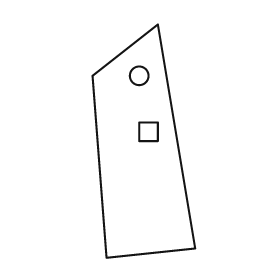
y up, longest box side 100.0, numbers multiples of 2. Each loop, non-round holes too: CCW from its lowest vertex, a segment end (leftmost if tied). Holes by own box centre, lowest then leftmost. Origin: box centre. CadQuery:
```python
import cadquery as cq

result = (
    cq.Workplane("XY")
    .moveTo(-16.0, -50.0)
    .lineTo(22.0, -46.0)
    .lineTo(6.0, 50.0)
    .lineTo(-22.0, 28.0)
    .close()
    .moveTo(-2.0, 0.0)
    .lineTo(6.0, 0.0)
    .lineTo(6.0, 8.0)
    .lineTo(-2.0, 8.0)
    .close()
    .moveTo(-2.0, 28.0)
    .circle(4.0)
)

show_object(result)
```